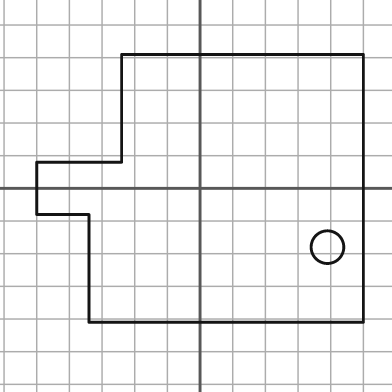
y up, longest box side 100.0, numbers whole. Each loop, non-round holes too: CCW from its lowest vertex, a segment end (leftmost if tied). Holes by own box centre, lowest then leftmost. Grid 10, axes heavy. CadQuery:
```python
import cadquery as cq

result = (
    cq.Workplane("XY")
    .moveTo(-34.0, -41.0)
    .lineTo(50.0, -41.0)
    .lineTo(50.0, 41.0)
    .lineTo(-24.0, 41.0)
    .lineTo(-24.0, 8.0)
    .lineTo(-50.0, 8.0)
    .lineTo(-50.0, -8.0)
    .lineTo(-34.0, -8.0)
    .close()
    .moveTo(39.0, -18.0)
    .circle(5.0)
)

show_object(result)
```